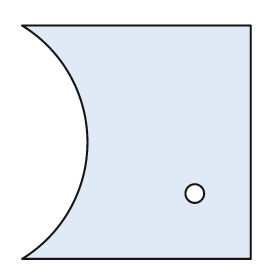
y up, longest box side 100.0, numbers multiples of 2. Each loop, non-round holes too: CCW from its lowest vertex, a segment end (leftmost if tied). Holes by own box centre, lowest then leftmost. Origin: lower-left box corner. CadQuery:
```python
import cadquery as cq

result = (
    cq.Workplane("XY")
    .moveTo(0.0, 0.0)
    .lineTo(98.0, 0.0)
    .lineTo(98.0, 100.0)
    .lineTo(0.0, 100.0)
    .threePointArc((28.0, 50.0), (0.0, 0.0))
    .close()
    .moveTo(74.0, 28.0)
    .circle(4.0)
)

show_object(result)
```